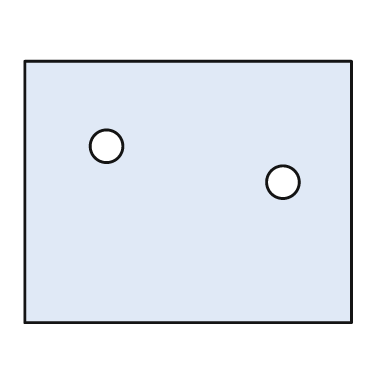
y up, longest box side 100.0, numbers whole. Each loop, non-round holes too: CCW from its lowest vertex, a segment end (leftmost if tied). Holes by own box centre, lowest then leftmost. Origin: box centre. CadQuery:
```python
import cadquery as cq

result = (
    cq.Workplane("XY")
    .moveTo(-50.0, -40.0)
    .lineTo(50.0, -40.0)
    .lineTo(50.0, 40.0)
    .lineTo(-50.0, 40.0)
    .close()
    .moveTo(29.0, 3.0)
    .circle(5.0)
    .moveTo(-25.0, 14.0)
    .circle(5.0)
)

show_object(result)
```